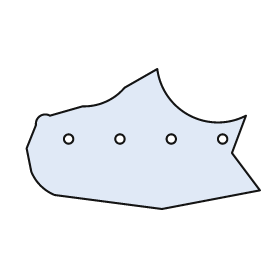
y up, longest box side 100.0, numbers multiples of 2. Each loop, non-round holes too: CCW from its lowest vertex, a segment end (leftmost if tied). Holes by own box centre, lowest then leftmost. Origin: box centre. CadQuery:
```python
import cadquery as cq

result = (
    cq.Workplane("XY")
    .moveTo(8.0, -30.0)
    .lineTo(50.0, -22.0)
    .lineTo(38.0, -6.0)
    .lineTo(44.0, 10.0)
    .threePointArc((20.0, 10.0), (6.0, 30.0))
    .lineTo(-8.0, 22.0)
    .threePointArc((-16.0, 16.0), (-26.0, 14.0))
    .lineTo(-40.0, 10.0)
    .threePointArc((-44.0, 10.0), (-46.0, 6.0))
    .lineTo(-50.0, -4.0)
    .lineTo(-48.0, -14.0)
    .threePointArc((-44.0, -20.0), (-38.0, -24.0))
    .close()
    .moveTo(-32.0, 0.0)
    .circle(2.0)
    .moveTo(-10.0, 0.0)
    .circle(2.0)
    .moveTo(12.0, 0.0)
    .circle(2.0)
    .moveTo(34.0, 0.0)
    .circle(2.0)
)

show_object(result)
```